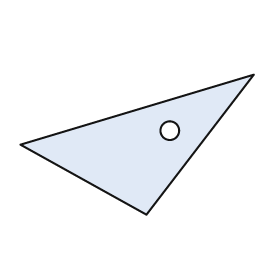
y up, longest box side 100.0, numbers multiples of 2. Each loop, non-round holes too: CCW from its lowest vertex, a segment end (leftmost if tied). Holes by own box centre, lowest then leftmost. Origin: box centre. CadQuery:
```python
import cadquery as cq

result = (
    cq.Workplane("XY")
    .moveTo(4.0, -30.0)
    .lineTo(50.0, 30.0)
    .lineTo(-50.0, 0.0)
    .close()
    .moveTo(14.0, 6.0)
    .circle(4.0)
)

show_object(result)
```